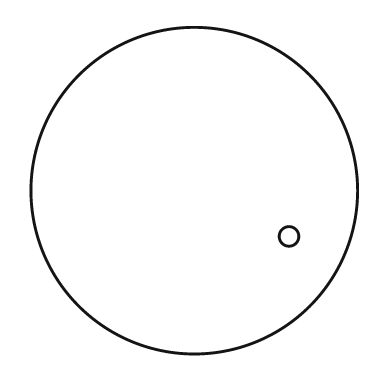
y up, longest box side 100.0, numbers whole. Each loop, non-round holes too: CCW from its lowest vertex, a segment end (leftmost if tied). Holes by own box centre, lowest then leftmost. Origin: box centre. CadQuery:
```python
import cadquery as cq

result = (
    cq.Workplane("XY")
    .moveTo(0.0, 0.0)
    .circle(50.0)
    .moveTo(29.0, -14.0)
    .circle(3.0)
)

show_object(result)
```